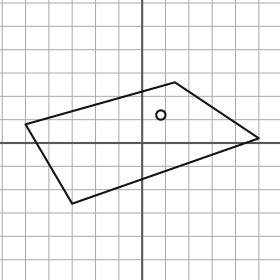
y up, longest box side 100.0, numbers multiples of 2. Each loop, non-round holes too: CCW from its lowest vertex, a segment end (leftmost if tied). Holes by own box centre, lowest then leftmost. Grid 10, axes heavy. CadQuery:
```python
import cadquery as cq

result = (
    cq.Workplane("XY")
    .moveTo(-30.0, -26.0)
    .lineTo(50.0, 2.0)
    .lineTo(14.0, 26.0)
    .lineTo(-50.0, 8.0)
    .close()
    .moveTo(8.0, 12.0)
    .circle(2.0)
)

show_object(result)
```